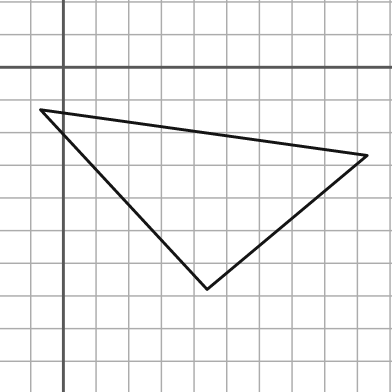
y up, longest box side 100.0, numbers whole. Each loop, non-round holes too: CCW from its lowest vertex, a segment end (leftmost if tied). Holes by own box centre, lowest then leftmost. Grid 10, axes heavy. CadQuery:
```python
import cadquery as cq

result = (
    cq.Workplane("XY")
    .moveTo(44.0, -68.0)
    .lineTo(93.0, -27.0)
    .lineTo(-7.0, -13.0)
    .close()
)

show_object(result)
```